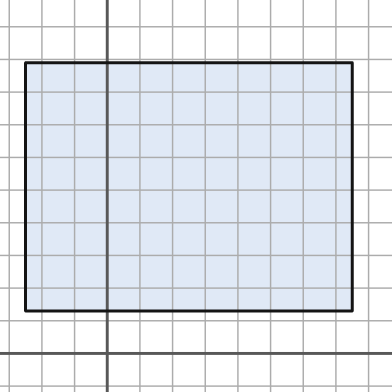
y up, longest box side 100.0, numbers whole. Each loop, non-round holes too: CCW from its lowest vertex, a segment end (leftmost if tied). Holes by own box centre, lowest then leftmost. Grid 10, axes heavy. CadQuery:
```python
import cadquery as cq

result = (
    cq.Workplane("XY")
    .moveTo(-25.0, 13.0)
    .lineTo(75.0, 13.0)
    .lineTo(75.0, 89.0)
    .lineTo(-25.0, 89.0)
    .close()
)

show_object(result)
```